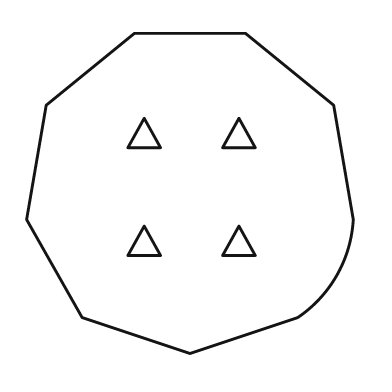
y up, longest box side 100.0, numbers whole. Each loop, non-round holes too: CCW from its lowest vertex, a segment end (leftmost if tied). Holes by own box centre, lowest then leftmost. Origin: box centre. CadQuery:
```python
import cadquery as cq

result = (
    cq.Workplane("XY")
    .moveTo(0.0, -49.0)
    .lineTo(33.0, -38.0)
    .threePointArc((45.0, -25.0), (50.0, -8.0))
    .lineTo(44.0, 27.0)
    .lineTo(17.0, 49.0)
    .lineTo(-17.0, 49.0)
    .lineTo(-44.0, 27.0)
    .lineTo(-50.0, -8.0)
    .lineTo(-33.0, -38.0)
    .close()
    .moveTo(-19.0, -19.0)
    .lineTo(-9.0, -19.0)
    .lineTo(-14.0, -10.0)
    .close()
    .moveTo(10.0, -19.0)
    .lineTo(20.0, -19.0)
    .lineTo(15.0, -10.0)
    .close()
    .moveTo(-19.0, 14.0)
    .lineTo(-9.0, 14.0)
    .lineTo(-14.0, 23.0)
    .close()
    .moveTo(10.0, 14.0)
    .lineTo(20.0, 14.0)
    .lineTo(15.0, 23.0)
    .close()
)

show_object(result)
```